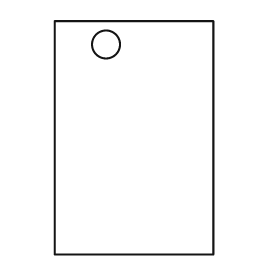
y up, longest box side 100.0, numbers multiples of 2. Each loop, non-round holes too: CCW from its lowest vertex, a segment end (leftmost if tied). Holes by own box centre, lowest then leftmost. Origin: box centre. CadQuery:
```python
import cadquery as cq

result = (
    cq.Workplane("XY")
    .moveTo(-34.0, -50.0)
    .lineTo(34.0, -50.0)
    .lineTo(34.0, 50.0)
    .lineTo(-34.0, 50.0)
    .close()
    .moveTo(-12.0, 40.0)
    .circle(6.0)
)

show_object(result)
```